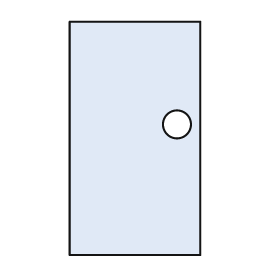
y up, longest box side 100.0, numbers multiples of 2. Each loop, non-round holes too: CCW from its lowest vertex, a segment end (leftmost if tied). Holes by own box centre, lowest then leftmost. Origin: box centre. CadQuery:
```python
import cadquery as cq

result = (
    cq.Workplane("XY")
    .moveTo(-28.0, -50.0)
    .lineTo(28.0, -50.0)
    .lineTo(28.0, 50.0)
    .lineTo(-28.0, 50.0)
    .close()
    .moveTo(18.0, 6.0)
    .circle(6.0)
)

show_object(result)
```